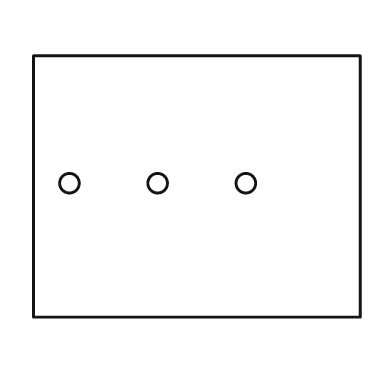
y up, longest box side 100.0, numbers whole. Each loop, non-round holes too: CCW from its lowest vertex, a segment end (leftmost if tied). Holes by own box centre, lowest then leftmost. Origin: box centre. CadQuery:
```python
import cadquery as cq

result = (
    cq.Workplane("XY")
    .moveTo(-50.0, -40.0)
    .lineTo(50.0, -40.0)
    .lineTo(50.0, 40.0)
    .lineTo(-50.0, 40.0)
    .close()
    .moveTo(-39.0, 1.0)
    .circle(3.0)
    .moveTo(-12.0, 1.0)
    .circle(3.0)
    .moveTo(15.0, 1.0)
    .circle(3.0)
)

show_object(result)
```